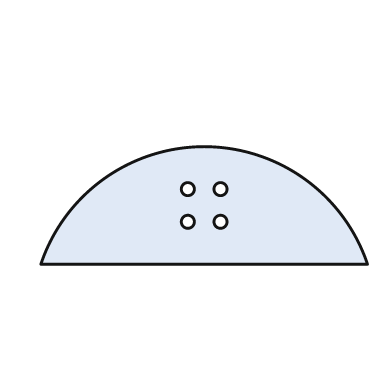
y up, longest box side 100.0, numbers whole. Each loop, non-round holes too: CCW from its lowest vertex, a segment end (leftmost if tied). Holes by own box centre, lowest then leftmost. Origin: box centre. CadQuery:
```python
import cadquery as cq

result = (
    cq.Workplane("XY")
    .moveTo(-50.0, -18.0)
    .lineTo(50.0, -18.0)
    .threePointArc((0.0, 18.0), (-50.0, -18.0))
    .close()
    .moveTo(-5.0, -5.0)
    .circle(2.0)
    .moveTo(5.0, -5.0)
    .circle(2.0)
    .moveTo(-5.0, 5.0)
    .circle(2.0)
    .moveTo(5.0, 5.0)
    .circle(2.0)
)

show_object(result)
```